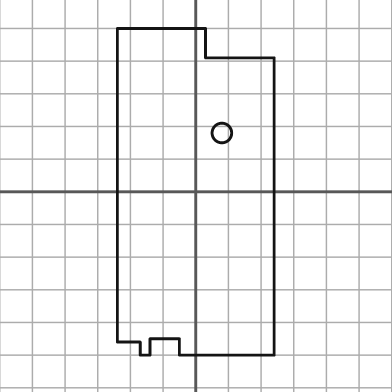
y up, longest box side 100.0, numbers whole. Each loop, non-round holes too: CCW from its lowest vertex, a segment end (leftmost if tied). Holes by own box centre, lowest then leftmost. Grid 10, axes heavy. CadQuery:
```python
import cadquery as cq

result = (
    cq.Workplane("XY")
    .moveTo(-17.0, -50.0)
    .lineTo(-14.0, -50.0)
    .lineTo(-14.0, -45.0)
    .lineTo(-5.0, -45.0)
    .lineTo(-5.0, -50.0)
    .lineTo(24.0, -50.0)
    .lineTo(24.0, 41.0)
    .lineTo(3.0, 41.0)
    .lineTo(3.0, 50.0)
    .lineTo(-24.0, 50.0)
    .lineTo(-24.0, -46.0)
    .lineTo(-17.0, -46.0)
    .close()
    .moveTo(8.0, 18.0)
    .circle(3.0)
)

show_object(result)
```